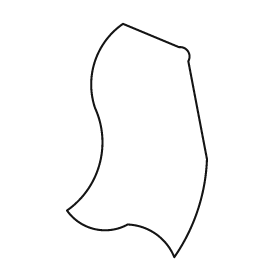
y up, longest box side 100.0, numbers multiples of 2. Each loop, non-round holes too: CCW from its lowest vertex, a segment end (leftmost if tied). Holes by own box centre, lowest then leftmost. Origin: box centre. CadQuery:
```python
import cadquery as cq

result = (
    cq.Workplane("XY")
    .moveTo(16.0, -50.0)
    .threePointArc((26.0, -30.0), (30.0, -8.0))
    .lineTo(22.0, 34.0)
    .threePointArc((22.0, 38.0), (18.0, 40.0))
    .lineTo(-6.0, 50.0)
    .threePointArc((-18.0, 34.0), (-18.0, 14.0))
    .threePointArc((-16.0, -10.0), (-30.0, -30.0))
    .threePointArc((-18.0, -38.0), (-4.0, -36.0))
    .threePointArc((8.0, -40.0), (16.0, -50.0))
    .close()
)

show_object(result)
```